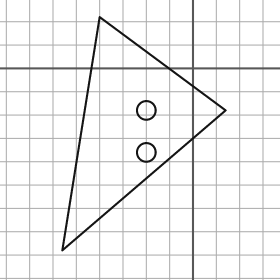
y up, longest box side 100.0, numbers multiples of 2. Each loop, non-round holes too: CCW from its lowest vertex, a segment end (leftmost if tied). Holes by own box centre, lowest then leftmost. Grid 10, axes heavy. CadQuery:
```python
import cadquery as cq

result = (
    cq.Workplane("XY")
    .moveTo(-56.0, -78.0)
    .lineTo(14.0, -18.0)
    .lineTo(-40.0, 22.0)
    .close()
    .moveTo(-20.0, -36.0)
    .circle(4.0)
    .moveTo(-20.0, -18.0)
    .circle(4.0)
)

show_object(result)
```